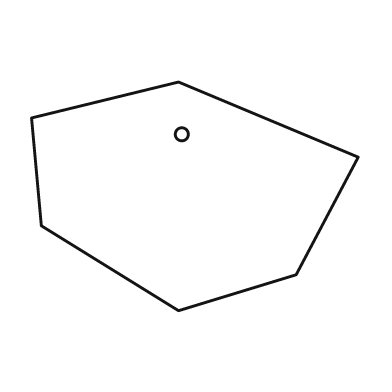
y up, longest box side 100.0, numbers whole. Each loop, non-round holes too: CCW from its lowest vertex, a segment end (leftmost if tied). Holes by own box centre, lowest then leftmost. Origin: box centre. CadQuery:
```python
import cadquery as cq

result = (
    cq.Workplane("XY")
    .moveTo(-5.0, -35.0)
    .lineTo(31.0, -24.0)
    .lineTo(50.0, 12.0)
    .lineTo(-5.0, 35.0)
    .lineTo(-50.0, 24.0)
    .lineTo(-47.0, -9.0)
    .close()
    .moveTo(-4.0, 19.0)
    .circle(2.0)
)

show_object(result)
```